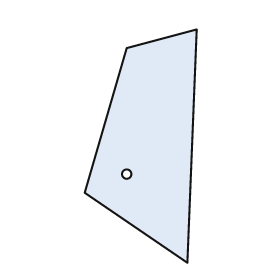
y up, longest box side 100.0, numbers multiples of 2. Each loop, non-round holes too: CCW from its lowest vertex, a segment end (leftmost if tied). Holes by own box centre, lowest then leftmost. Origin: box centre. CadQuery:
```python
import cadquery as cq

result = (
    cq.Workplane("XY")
    .moveTo(20.0, -50.0)
    .lineTo(24.0, 50.0)
    .lineTo(-6.0, 42.0)
    .lineTo(-24.0, -20.0)
    .close()
    .moveTo(-6.0, -12.0)
    .circle(2.0)
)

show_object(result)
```